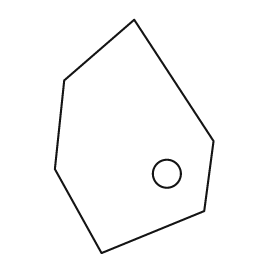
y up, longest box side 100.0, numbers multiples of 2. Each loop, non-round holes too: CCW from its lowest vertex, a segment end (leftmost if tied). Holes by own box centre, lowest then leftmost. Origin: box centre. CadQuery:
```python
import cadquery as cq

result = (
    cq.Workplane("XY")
    .moveTo(-14.0, -50.0)
    .lineTo(30.0, -32.0)
    .lineTo(34.0, -2.0)
    .lineTo(0.0, 50.0)
    .lineTo(-30.0, 24.0)
    .lineTo(-34.0, -14.0)
    .close()
    .moveTo(14.0, -16.0)
    .circle(6.0)
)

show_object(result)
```